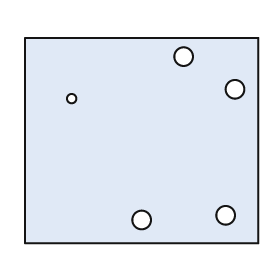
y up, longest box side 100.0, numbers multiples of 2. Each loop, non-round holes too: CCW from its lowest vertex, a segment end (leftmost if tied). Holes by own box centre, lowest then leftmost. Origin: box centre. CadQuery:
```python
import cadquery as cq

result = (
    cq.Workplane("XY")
    .moveTo(-50.0, -44.0)
    .lineTo(50.0, -44.0)
    .lineTo(50.0, 44.0)
    .lineTo(-50.0, 44.0)
    .close()
    .moveTo(0.0, -34.0)
    .circle(4.0)
    .moveTo(36.0, -32.0)
    .circle(4.0)
    .moveTo(-30.0, 18.0)
    .circle(2.0)
    .moveTo(40.0, 22.0)
    .circle(4.0)
    .moveTo(18.0, 36.0)
    .circle(4.0)
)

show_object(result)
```